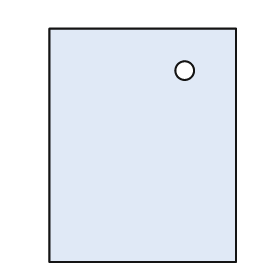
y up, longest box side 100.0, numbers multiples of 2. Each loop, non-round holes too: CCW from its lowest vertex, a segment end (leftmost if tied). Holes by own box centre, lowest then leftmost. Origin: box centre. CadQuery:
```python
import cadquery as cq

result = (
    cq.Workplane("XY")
    .moveTo(-40.0, -50.0)
    .lineTo(40.0, -50.0)
    .lineTo(40.0, 50.0)
    .lineTo(-40.0, 50.0)
    .close()
    .moveTo(18.0, 32.0)
    .circle(4.0)
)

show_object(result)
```